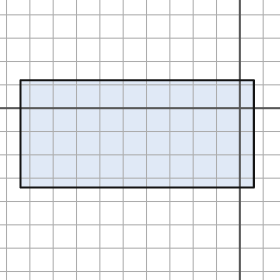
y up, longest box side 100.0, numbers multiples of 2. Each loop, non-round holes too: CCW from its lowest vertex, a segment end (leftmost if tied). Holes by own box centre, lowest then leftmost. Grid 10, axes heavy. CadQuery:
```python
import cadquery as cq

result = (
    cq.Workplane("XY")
    .moveTo(-94.0, -34.0)
    .lineTo(6.0, -34.0)
    .lineTo(6.0, 12.0)
    .lineTo(-94.0, 12.0)
    .close()
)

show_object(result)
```